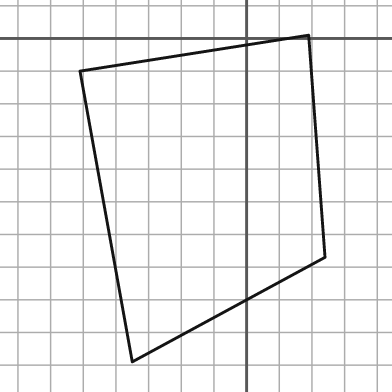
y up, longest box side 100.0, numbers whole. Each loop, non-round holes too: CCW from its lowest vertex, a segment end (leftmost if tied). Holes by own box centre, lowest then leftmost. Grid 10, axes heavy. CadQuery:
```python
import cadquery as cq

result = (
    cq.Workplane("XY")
    .moveTo(-35.0, -99.0)
    .lineTo(24.0, -67.0)
    .lineTo(19.0, 1.0)
    .lineTo(-51.0, -10.0)
    .close()
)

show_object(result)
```